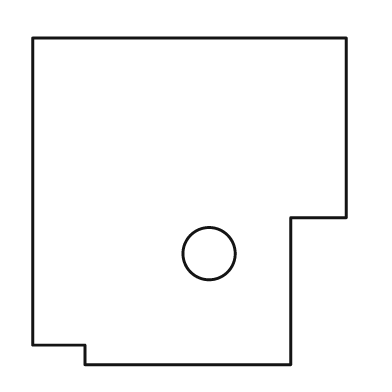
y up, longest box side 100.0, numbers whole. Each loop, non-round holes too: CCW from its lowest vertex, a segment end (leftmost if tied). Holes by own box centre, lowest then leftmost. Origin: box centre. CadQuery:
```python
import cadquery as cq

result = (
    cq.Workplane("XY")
    .moveTo(-32.0, -50.0)
    .lineTo(31.0, -50.0)
    .lineTo(31.0, -5.0)
    .lineTo(48.0, -5.0)
    .lineTo(48.0, 50.0)
    .lineTo(-48.0, 50.0)
    .lineTo(-48.0, -44.0)
    .lineTo(-32.0, -44.0)
    .close()
    .moveTo(6.0, -16.0)
    .circle(8.0)
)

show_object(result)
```